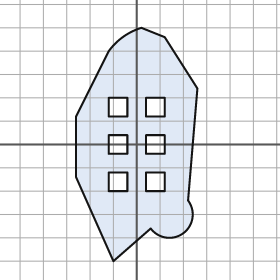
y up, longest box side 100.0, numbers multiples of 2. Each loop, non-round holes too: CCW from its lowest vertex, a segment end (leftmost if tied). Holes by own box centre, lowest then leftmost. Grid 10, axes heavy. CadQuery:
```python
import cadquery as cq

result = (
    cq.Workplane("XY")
    .moveTo(-10.0, -50.0)
    .lineTo(6.0, -36.0)
    .threePointArc((20.0, -38.0), (22.0, -24.0))
    .lineTo(26.0, 24.0)
    .lineTo(12.0, 46.0)
    .lineTo(2.0, 50.0)
    .threePointArc((-6.0, 46.0), (-12.0, 40.0))
    .lineTo(-26.0, 12.0)
    .lineTo(-26.0, -14.0)
    .close()
    .moveTo(-12.0, -20.0)
    .lineTo(-4.0, -20.0)
    .lineTo(-4.0, -12.0)
    .lineTo(-12.0, -12.0)
    .close()
    .moveTo(4.0, -20.0)
    .lineTo(12.0, -20.0)
    .lineTo(12.0, -12.0)
    .lineTo(4.0, -12.0)
    .close()
    .moveTo(-12.0, -4.0)
    .lineTo(-4.0, -4.0)
    .lineTo(-4.0, 4.0)
    .lineTo(-12.0, 4.0)
    .close()
    .moveTo(4.0, -4.0)
    .lineTo(12.0, -4.0)
    .lineTo(12.0, 4.0)
    .lineTo(4.0, 4.0)
    .close()
    .moveTo(-12.0, 12.0)
    .lineTo(-4.0, 12.0)
    .lineTo(-4.0, 20.0)
    .lineTo(-12.0, 20.0)
    .close()
    .moveTo(4.0, 12.0)
    .lineTo(12.0, 12.0)
    .lineTo(12.0, 20.0)
    .lineTo(4.0, 20.0)
    .close()
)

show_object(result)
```